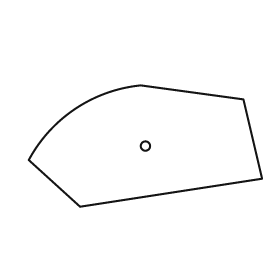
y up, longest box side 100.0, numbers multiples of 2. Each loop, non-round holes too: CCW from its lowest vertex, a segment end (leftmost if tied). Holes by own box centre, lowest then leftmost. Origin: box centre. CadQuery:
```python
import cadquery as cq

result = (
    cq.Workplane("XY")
    .moveTo(-28.0, -26.0)
    .lineTo(50.0, -14.0)
    .lineTo(42.0, 20.0)
    .lineTo(-2.0, 26.0)
    .threePointArc((-30.0, 16.0), (-50.0, -6.0))
    .close()
    .moveTo(0.0, 0.0)
    .circle(2.0)
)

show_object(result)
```